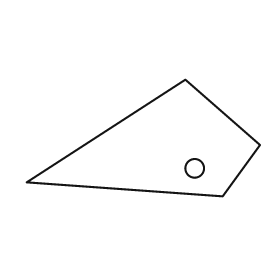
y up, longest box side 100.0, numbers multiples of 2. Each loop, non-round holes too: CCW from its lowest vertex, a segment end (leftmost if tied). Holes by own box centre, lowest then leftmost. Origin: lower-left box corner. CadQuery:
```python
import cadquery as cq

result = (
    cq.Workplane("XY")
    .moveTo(84.0, 0.0)
    .lineTo(100.0, 22.0)
    .lineTo(68.0, 50.0)
    .lineTo(0.0, 6.0)
    .close()
    .moveTo(72.0, 12.0)
    .circle(4.0)
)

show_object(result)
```